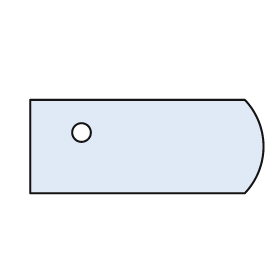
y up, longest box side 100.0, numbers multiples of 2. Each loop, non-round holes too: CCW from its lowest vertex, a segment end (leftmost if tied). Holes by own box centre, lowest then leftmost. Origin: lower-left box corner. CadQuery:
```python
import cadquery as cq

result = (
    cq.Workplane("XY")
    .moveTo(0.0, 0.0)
    .lineTo(92.0, 0.0)
    .threePointArc((100.0, 20.0), (92.0, 40.0))
    .lineTo(0.0, 40.0)
    .close()
    .moveTo(22.0, 26.0)
    .circle(4.0)
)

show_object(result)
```